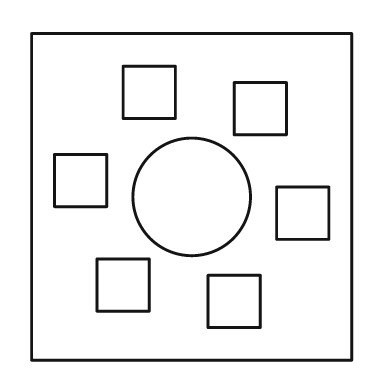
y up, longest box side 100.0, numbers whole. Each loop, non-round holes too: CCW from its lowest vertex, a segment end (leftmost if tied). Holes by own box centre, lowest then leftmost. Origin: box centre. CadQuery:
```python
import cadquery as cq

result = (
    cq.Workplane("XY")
    .moveTo(-49.0, -50.0)
    .lineTo(49.0, -50.0)
    .lineTo(49.0, 50.0)
    .lineTo(-49.0, 50.0)
    .close()
    .moveTo(5.0, -40.0)
    .lineTo(21.0, -40.0)
    .lineTo(21.0, -24.0)
    .lineTo(5.0, -24.0)
    .close()
    .moveTo(-29.0, -35.0)
    .lineTo(-13.0, -35.0)
    .lineTo(-13.0, -19.0)
    .lineTo(-29.0, -19.0)
    .close()
    .moveTo(26.0, -13.0)
    .lineTo(42.0, -13.0)
    .lineTo(42.0, 3.0)
    .lineTo(26.0, 3.0)
    .close()
    .moveTo(0.0, 0.0)
    .circle(18.0)
    .moveTo(-42.0, -3.0)
    .lineTo(-26.0, -3.0)
    .lineTo(-26.0, 13.0)
    .lineTo(-42.0, 13.0)
    .close()
    .moveTo(13.0, 19.0)
    .lineTo(29.0, 19.0)
    .lineTo(29.0, 35.0)
    .lineTo(13.0, 35.0)
    .close()
    .moveTo(-21.0, 24.0)
    .lineTo(-5.0, 24.0)
    .lineTo(-5.0, 40.0)
    .lineTo(-21.0, 40.0)
    .close()
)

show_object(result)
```